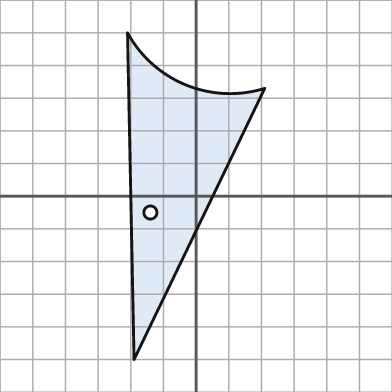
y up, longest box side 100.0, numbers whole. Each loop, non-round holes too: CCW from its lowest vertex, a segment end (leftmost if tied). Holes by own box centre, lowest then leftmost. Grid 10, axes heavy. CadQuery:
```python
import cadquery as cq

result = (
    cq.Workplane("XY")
    .moveTo(-19.0, -50.0)
    .lineTo(21.0, 33.0)
    .threePointArc((-3.0, 34.0), (-21.0, 50.0))
    .close()
    .moveTo(-14.0, -5.0)
    .circle(2.0)
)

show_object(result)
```